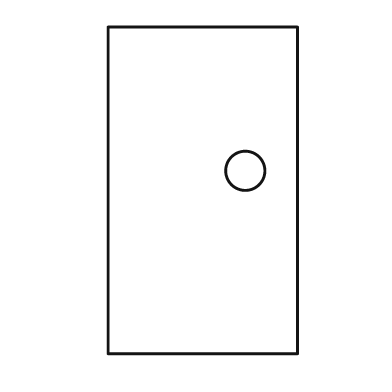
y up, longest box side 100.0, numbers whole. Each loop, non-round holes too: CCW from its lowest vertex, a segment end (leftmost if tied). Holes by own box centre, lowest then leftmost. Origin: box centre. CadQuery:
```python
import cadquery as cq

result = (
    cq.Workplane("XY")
    .moveTo(-29.0, -50.0)
    .lineTo(29.0, -50.0)
    .lineTo(29.0, 50.0)
    .lineTo(-29.0, 50.0)
    .close()
    .moveTo(13.0, 6.0)
    .circle(6.0)
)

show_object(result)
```